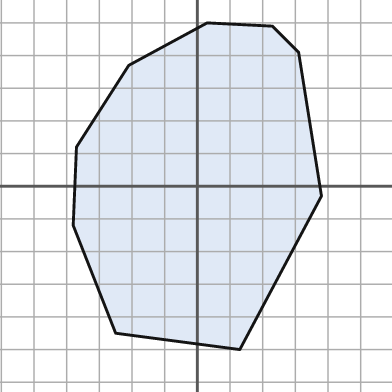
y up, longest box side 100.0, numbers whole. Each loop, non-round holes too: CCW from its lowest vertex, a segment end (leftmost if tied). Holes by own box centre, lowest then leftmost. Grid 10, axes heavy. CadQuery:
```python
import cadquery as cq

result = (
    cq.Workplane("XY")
    .moveTo(13.0, -50.0)
    .lineTo(38.0, -3.0)
    .lineTo(31.0, 41.0)
    .lineTo(23.0, 49.0)
    .lineTo(3.0, 50.0)
    .lineTo(-21.0, 37.0)
    .lineTo(-37.0, 12.0)
    .lineTo(-38.0, -12.0)
    .lineTo(-25.0, -45.0)
    .close()
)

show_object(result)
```